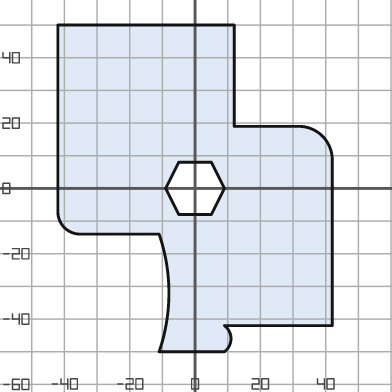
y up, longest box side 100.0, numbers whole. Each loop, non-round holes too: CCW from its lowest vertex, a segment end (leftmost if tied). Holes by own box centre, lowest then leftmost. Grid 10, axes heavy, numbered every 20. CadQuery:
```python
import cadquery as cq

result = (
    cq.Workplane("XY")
    .moveTo(-11.0, -50.0)
    .lineTo(9.0, -50.0)
    .threePointArc((11.0, -46.0), (9.0, -42.0))
    .lineTo(42.0, -42.0)
    .lineTo(42.0, 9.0)
    .threePointArc((39.0, 16.0), (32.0, 19.0))
    .lineTo(12.0, 19.0)
    .lineTo(12.0, 50.0)
    .lineTo(-42.0, 50.0)
    .lineTo(-42.0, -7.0)
    .threePointArc((-40.0, -12.0), (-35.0, -14.0))
    .lineTo(-11.0, -14.0)
    .threePointArc((-8.0, -32.0), (-11.0, -50.0))
    .close()
    .moveTo(-5.0, -8.0)
    .lineTo(5.0, -8.0)
    .lineTo(9.0, 0.0)
    .lineTo(5.0, 8.0)
    .lineTo(-5.0, 8.0)
    .lineTo(-9.0, 0.0)
    .close()
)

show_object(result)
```